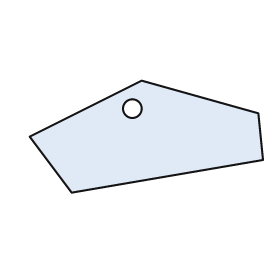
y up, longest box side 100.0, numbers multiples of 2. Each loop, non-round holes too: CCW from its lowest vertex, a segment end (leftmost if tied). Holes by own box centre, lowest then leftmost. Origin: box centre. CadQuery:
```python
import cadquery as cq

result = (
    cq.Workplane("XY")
    .moveTo(-32.0, -24.0)
    .lineTo(50.0, -10.0)
    .lineTo(48.0, 10.0)
    .lineTo(-2.0, 24.0)
    .lineTo(-50.0, 0.0)
    .close()
    .moveTo(-6.0, 12.0)
    .circle(4.0)
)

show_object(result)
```